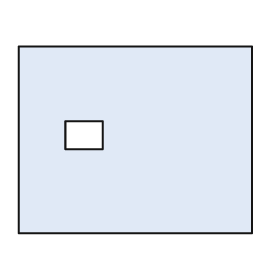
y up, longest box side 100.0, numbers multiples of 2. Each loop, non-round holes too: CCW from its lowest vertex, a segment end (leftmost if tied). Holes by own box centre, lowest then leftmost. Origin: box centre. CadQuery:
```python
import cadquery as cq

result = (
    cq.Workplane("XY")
    .moveTo(-50.0, -40.0)
    .lineTo(50.0, -40.0)
    .lineTo(50.0, 40.0)
    .lineTo(-50.0, 40.0)
    .close()
    .moveTo(-30.0, -4.0)
    .lineTo(-14.0, -4.0)
    .lineTo(-14.0, 8.0)
    .lineTo(-30.0, 8.0)
    .close()
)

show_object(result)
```